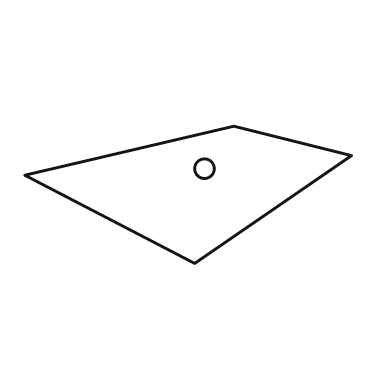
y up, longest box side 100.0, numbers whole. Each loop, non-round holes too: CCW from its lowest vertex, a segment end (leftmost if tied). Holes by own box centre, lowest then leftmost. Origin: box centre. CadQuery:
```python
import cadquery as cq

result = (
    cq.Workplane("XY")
    .moveTo(2.0, -21.0)
    .lineTo(50.0, 12.0)
    .lineTo(14.0, 21.0)
    .lineTo(-50.0, 6.0)
    .close()
    .moveTo(5.0, 8.0)
    .circle(3.0)
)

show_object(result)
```